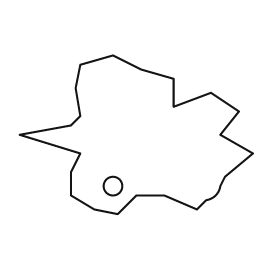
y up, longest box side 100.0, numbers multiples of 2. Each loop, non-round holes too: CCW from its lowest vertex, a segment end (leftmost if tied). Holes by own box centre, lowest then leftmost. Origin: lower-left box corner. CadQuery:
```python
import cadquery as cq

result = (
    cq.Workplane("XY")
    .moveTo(42.0, 0.0)
    .lineTo(50.0, 8.0)
    .lineTo(62.0, 8.0)
    .lineTo(76.0, 2.0)
    .lineTo(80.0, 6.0)
    .threePointArc((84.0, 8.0), (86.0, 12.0))
    .lineTo(88.0, 16.0)
    .lineTo(100.0, 26.0)
    .lineTo(86.0, 34.0)
    .lineTo(94.0, 44.0)
    .lineTo(82.0, 52.0)
    .lineTo(66.0, 46.0)
    .lineTo(66.0, 58.0)
    .lineTo(52.0, 62.0)
    .lineTo(40.0, 68.0)
    .lineTo(26.0, 64.0)
    .lineTo(24.0, 54.0)
    .lineTo(26.0, 42.0)
    .lineTo(22.0, 38.0)
    .lineTo(0.0, 34.0)
    .lineTo(26.0, 26.0)
    .lineTo(22.0, 18.0)
    .lineTo(22.0, 8.0)
    .lineTo(32.0, 2.0)
    .close()
    .moveTo(40.0, 12.0)
    .circle(4.0)
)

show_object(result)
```